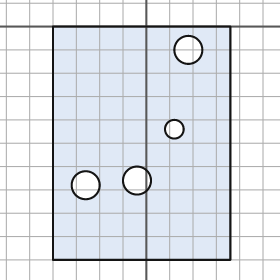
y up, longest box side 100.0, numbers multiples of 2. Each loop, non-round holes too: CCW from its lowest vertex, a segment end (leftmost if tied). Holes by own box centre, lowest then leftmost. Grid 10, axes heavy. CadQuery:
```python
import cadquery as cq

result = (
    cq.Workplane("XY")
    .moveTo(-40.0, -100.0)
    .lineTo(36.0, -100.0)
    .lineTo(36.0, 0.0)
    .lineTo(-40.0, 0.0)
    .close()
    .moveTo(-26.0, -68.0)
    .circle(6.0)
    .moveTo(-4.0, -66.0)
    .circle(6.0)
    .moveTo(12.0, -44.0)
    .circle(4.0)
    .moveTo(18.0, -10.0)
    .circle(6.0)
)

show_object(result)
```